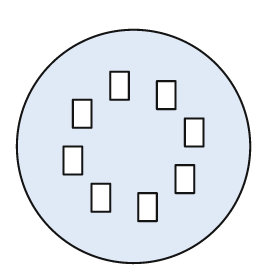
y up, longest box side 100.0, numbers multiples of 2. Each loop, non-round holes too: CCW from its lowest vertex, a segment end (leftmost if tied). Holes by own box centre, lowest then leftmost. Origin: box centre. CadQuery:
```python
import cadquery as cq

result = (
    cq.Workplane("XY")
    .moveTo(0.0, 0.0)
    .circle(50.0)
    .moveTo(2.0, -32.0)
    .lineTo(10.0, -32.0)
    .lineTo(10.0, -20.0)
    .lineTo(2.0, -20.0)
    .close()
    .moveTo(-18.0, -28.0)
    .lineTo(-10.0, -28.0)
    .lineTo(-10.0, -16.0)
    .lineTo(-18.0, -16.0)
    .close()
    .moveTo(18.0, -20.0)
    .lineTo(26.0, -20.0)
    .lineTo(26.0, -8.0)
    .lineTo(18.0, -8.0)
    .close()
    .moveTo(-30.0, -12.0)
    .lineTo(-22.0, -12.0)
    .lineTo(-22.0, 0.0)
    .lineTo(-30.0, 0.0)
    .close()
    .moveTo(22.0, 0.0)
    .lineTo(30.0, 0.0)
    .lineTo(30.0, 12.0)
    .lineTo(22.0, 12.0)
    .close()
    .moveTo(-26.0, 8.0)
    .lineTo(-18.0, 8.0)
    .lineTo(-18.0, 20.0)
    .lineTo(-26.0, 20.0)
    .close()
    .moveTo(10.0, 16.0)
    .lineTo(18.0, 16.0)
    .lineTo(18.0, 28.0)
    .lineTo(10.0, 28.0)
    .close()
    .moveTo(-10.0, 20.0)
    .lineTo(-2.0, 20.0)
    .lineTo(-2.0, 32.0)
    .lineTo(-10.0, 32.0)
    .close()
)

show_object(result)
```